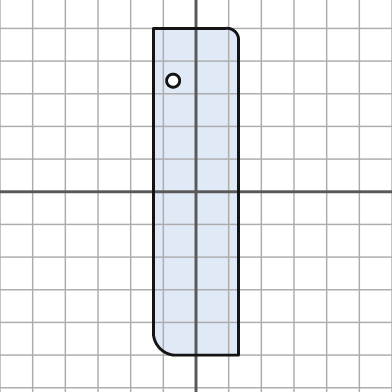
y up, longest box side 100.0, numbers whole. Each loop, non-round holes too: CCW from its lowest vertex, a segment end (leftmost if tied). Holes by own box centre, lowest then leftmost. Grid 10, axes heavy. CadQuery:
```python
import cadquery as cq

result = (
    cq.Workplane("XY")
    .moveTo(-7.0, -50.0)
    .lineTo(13.0, -50.0)
    .lineTo(13.0, 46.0)
    .threePointArc((12.0, 49.0), (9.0, 50.0))
    .lineTo(-13.0, 50.0)
    .lineTo(-13.0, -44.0)
    .threePointArc((-11.0, -48.0), (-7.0, -50.0))
    .close()
    .moveTo(-7.0, 34.0)
    .circle(2.0)
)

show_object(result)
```